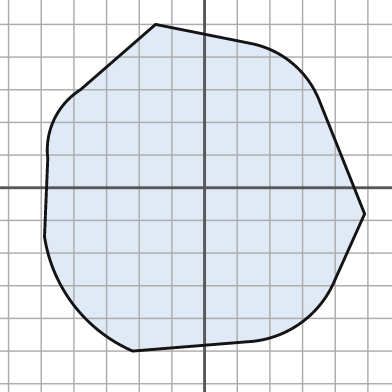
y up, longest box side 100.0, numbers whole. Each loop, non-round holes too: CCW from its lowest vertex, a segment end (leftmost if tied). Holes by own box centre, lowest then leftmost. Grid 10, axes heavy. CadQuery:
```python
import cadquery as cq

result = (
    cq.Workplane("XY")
    .moveTo(-22.0, -50.0)
    .lineTo(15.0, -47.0)
    .threePointArc((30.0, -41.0), (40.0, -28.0))
    .lineTo(49.0, -8.0)
    .lineTo(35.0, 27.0)
    .threePointArc((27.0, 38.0), (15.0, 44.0))
    .lineTo(-15.0, 50.0)
    .lineTo(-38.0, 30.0)
    .threePointArc((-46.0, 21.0), (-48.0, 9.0))
    .lineTo(-49.0, -15.0)
    .threePointArc((-40.0, -36.0), (-22.0, -50.0))
    .close()
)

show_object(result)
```